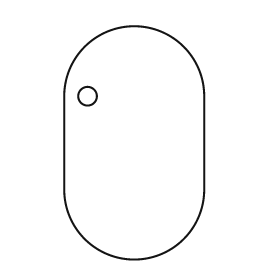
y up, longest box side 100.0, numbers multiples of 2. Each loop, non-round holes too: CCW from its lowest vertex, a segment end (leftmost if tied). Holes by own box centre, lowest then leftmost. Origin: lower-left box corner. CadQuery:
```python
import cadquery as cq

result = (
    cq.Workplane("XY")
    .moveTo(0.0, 30.0)
    .threePointArc((30.0, 0.0), (60.0, 30.0))
    .lineTo(60.0, 70.0)
    .threePointArc((30.0, 100.0), (0.0, 70.0))
    .close()
    .moveTo(10.0, 70.0)
    .circle(4.0)
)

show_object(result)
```